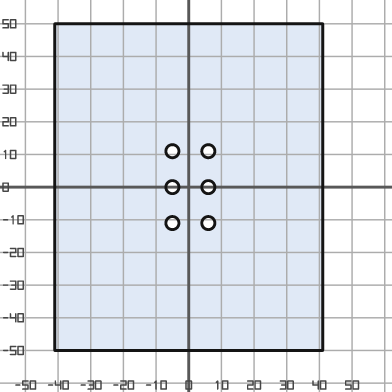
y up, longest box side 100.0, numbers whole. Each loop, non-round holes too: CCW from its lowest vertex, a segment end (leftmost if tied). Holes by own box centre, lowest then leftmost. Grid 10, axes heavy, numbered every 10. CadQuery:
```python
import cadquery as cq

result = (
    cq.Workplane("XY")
    .moveTo(-41.0, -50.0)
    .lineTo(41.0, -50.0)
    .lineTo(41.0, 50.0)
    .lineTo(-41.0, 50.0)
    .close()
    .moveTo(-5.0, -11.0)
    .circle(2.0)
    .moveTo(6.0, -11.0)
    .circle(2.0)
    .moveTo(-5.0, 0.0)
    .circle(2.0)
    .moveTo(6.0, 0.0)
    .circle(2.0)
    .moveTo(-5.0, 11.0)
    .circle(2.0)
    .moveTo(6.0, 11.0)
    .circle(2.0)
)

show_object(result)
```